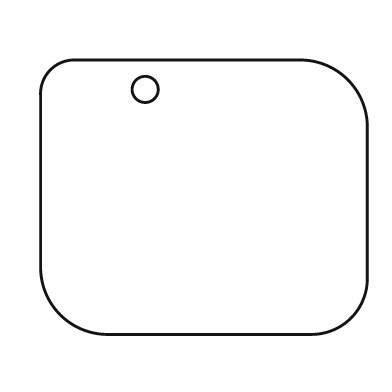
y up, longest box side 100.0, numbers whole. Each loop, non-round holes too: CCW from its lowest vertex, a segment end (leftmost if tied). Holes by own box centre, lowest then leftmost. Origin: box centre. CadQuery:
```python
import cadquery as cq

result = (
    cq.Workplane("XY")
    .moveTo(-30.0, -42.0)
    .lineTo(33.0, -42.0)
    .threePointArc((45.0, -37.0), (50.0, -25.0))
    .lineTo(50.0, 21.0)
    .threePointArc((44.0, 36.0), (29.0, 42.0))
    .lineTo(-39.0, 42.0)
    .threePointArc((-47.0, 39.0), (-50.0, 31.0))
    .lineTo(-50.0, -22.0)
    .threePointArc((-44.0, -36.0), (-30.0, -42.0))
    .close()
    .moveTo(-18.0, 33.0)
    .circle(4.0)
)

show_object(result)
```